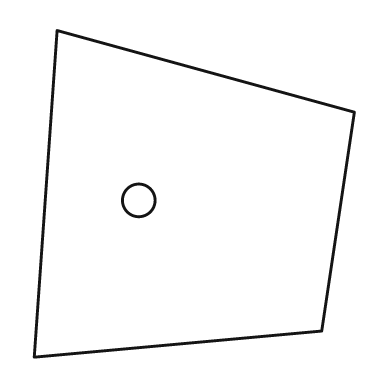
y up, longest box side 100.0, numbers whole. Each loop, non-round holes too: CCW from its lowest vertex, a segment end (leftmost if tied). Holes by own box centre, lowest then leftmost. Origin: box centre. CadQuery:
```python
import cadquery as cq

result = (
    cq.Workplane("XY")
    .moveTo(-49.0, -50.0)
    .lineTo(39.0, -42.0)
    .lineTo(49.0, 25.0)
    .lineTo(-42.0, 50.0)
    .close()
    .moveTo(-17.0, -2.0)
    .circle(5.0)
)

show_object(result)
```